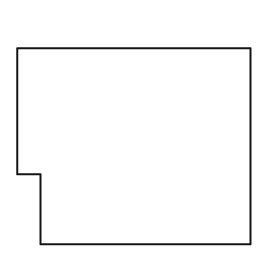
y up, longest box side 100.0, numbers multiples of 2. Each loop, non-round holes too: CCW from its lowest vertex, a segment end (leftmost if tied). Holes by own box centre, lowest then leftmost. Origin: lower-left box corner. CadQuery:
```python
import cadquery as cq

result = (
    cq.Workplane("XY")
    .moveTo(10.0, 0.0)
    .lineTo(100.0, 0.0)
    .lineTo(100.0, 84.0)
    .lineTo(0.0, 84.0)
    .lineTo(0.0, 30.0)
    .lineTo(10.0, 30.0)
    .close()
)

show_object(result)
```